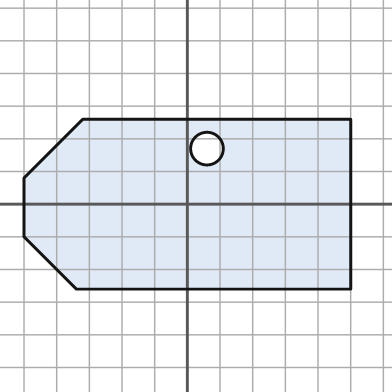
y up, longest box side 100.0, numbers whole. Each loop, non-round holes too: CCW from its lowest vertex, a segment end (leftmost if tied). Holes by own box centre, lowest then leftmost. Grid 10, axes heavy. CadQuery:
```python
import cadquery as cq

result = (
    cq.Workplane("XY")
    .moveTo(-34.0, -26.0)
    .lineTo(50.0, -26.0)
    .lineTo(50.0, 26.0)
    .lineTo(-32.0, 26.0)
    .lineTo(-50.0, 8.0)
    .lineTo(-50.0, -10.0)
    .close()
    .moveTo(6.0, 17.0)
    .circle(5.0)
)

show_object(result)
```